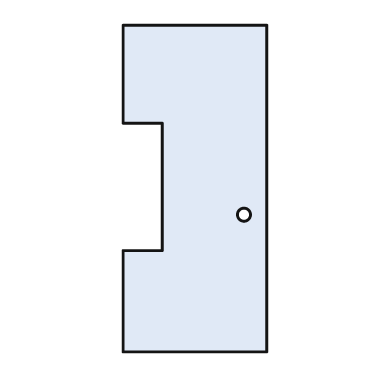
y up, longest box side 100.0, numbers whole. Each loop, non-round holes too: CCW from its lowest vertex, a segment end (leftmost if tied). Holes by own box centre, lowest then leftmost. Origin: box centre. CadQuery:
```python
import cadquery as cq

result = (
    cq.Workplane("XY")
    .moveTo(-22.0, -50.0)
    .lineTo(22.0, -50.0)
    .lineTo(22.0, 50.0)
    .lineTo(-22.0, 50.0)
    .lineTo(-22.0, 20.0)
    .lineTo(-10.0, 20.0)
    .lineTo(-10.0, -19.0)
    .lineTo(-22.0, -19.0)
    .close()
    .moveTo(15.0, -8.0)
    .circle(2.0)
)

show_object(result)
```